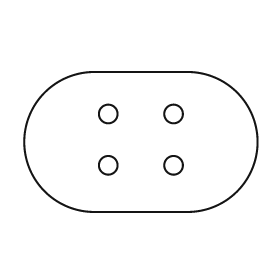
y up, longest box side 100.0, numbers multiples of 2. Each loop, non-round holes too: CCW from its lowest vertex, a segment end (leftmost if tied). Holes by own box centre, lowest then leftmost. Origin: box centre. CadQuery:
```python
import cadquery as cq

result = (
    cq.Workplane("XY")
    .moveTo(-20.0, -30.0)
    .lineTo(20.0, -30.0)
    .threePointArc((50.0, 0.0), (20.0, 30.0))
    .lineTo(-20.0, 30.0)
    .threePointArc((-50.0, 0.0), (-20.0, -30.0))
    .close()
    .moveTo(-14.0, -10.0)
    .circle(4.0)
    .moveTo(14.0, -10.0)
    .circle(4.0)
    .moveTo(-14.0, 12.0)
    .circle(4.0)
    .moveTo(14.0, 12.0)
    .circle(4.0)
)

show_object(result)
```